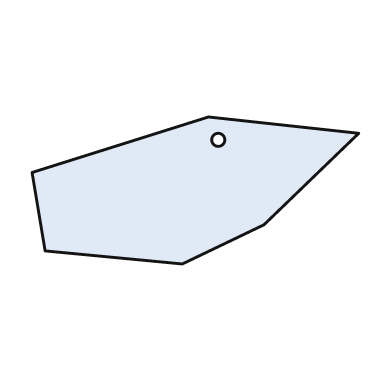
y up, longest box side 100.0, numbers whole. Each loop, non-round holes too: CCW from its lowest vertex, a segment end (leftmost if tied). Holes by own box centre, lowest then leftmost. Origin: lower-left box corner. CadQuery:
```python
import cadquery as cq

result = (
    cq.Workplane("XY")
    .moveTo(46.0, 0.0)
    .lineTo(71.0, 12.0)
    .lineTo(100.0, 40.0)
    .lineTo(54.0, 45.0)
    .lineTo(0.0, 28.0)
    .lineTo(4.0, 4.0)
    .close()
    .moveTo(57.0, 38.0)
    .circle(2.0)
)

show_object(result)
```